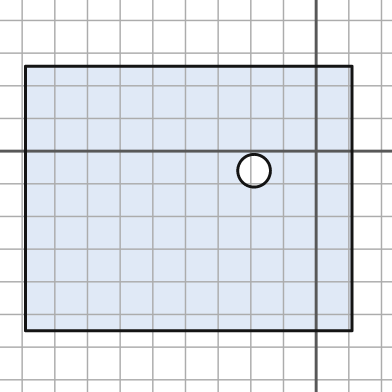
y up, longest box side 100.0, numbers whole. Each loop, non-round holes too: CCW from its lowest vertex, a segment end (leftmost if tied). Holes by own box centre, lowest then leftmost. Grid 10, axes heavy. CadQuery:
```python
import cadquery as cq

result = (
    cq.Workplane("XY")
    .moveTo(-89.0, -55.0)
    .lineTo(11.0, -55.0)
    .lineTo(11.0, 26.0)
    .lineTo(-89.0, 26.0)
    .close()
    .moveTo(-19.0, -6.0)
    .circle(5.0)
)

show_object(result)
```